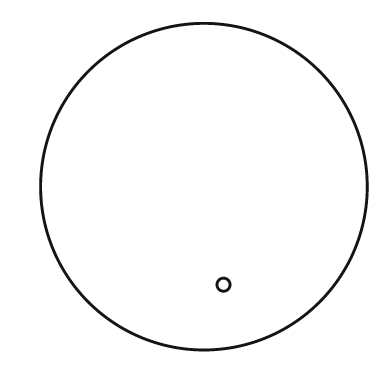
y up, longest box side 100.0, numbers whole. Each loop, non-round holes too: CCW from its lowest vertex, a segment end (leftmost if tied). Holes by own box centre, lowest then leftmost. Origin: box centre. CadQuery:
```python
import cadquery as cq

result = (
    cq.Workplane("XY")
    .moveTo(0.0, 0.0)
    .circle(50.0)
    .moveTo(6.0, -30.0)
    .circle(2.0)
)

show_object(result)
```